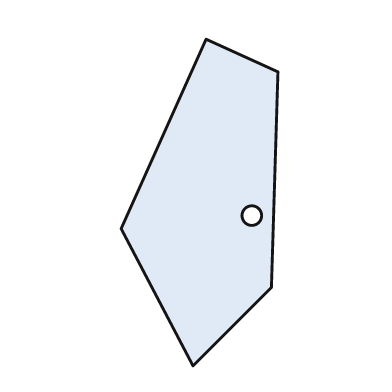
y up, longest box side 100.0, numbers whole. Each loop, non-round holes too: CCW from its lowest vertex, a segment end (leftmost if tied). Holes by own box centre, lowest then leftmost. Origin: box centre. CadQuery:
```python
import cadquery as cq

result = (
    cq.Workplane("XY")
    .moveTo(-2.0, -50.0)
    .lineTo(22.0, -26.0)
    .lineTo(24.0, 40.0)
    .lineTo(2.0, 50.0)
    .lineTo(-24.0, -8.0)
    .close()
    .moveTo(16.0, -4.0)
    .circle(3.0)
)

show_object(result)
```